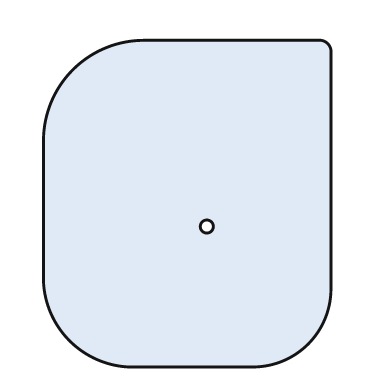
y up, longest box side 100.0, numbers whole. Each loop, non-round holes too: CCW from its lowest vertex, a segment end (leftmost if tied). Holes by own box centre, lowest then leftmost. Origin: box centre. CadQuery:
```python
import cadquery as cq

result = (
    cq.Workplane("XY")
    .moveTo(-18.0, -50.0)
    .lineTo(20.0, -50.0)
    .threePointArc((37.0, -43.0), (44.0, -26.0))
    .lineTo(44.0, 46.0)
    .threePointArc((43.0, 49.0), (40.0, 50.0))
    .lineTo(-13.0, 50.0)
    .threePointArc((-35.0, 41.0), (-44.0, 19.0))
    .lineTo(-44.0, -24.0)
    .threePointArc((-36.0, -42.0), (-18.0, -50.0))
    .close()
    .moveTo(6.0, -7.0)
    .circle(2.0)
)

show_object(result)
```